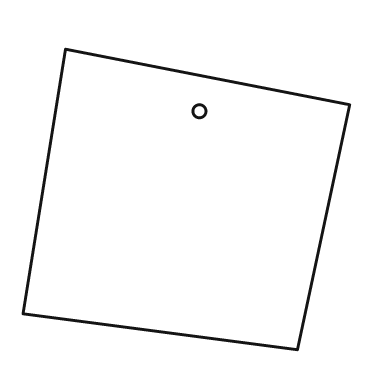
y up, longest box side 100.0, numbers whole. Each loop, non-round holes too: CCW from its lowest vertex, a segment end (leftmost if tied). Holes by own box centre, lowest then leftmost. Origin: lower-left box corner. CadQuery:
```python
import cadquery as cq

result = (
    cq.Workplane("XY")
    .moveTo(84.0, 0.0)
    .lineTo(100.0, 75.0)
    .lineTo(13.0, 92.0)
    .lineTo(0.0, 11.0)
    .close()
    .moveTo(54.0, 73.0)
    .circle(2.0)
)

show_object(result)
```